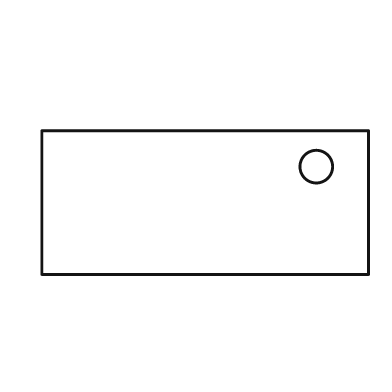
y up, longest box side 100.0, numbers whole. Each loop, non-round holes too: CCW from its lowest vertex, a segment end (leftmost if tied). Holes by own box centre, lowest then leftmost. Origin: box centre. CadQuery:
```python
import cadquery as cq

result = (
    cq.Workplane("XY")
    .moveTo(-50.0, -22.0)
    .lineTo(50.0, -22.0)
    .lineTo(50.0, 22.0)
    .lineTo(-50.0, 22.0)
    .close()
    .moveTo(34.0, 11.0)
    .circle(5.0)
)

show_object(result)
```